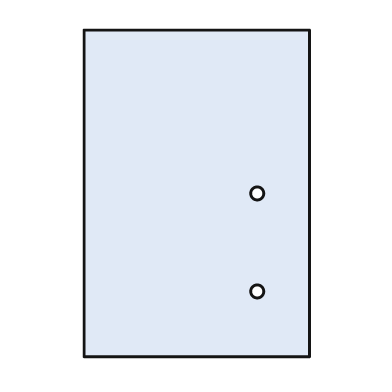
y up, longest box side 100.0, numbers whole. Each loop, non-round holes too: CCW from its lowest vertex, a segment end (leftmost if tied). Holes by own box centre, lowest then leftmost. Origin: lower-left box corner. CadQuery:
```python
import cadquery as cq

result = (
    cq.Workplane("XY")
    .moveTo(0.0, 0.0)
    .lineTo(69.0, 0.0)
    .lineTo(69.0, 100.0)
    .lineTo(0.0, 100.0)
    .close()
    .moveTo(53.0, 20.0)
    .circle(2.0)
    .moveTo(53.0, 50.0)
    .circle(2.0)
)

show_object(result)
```